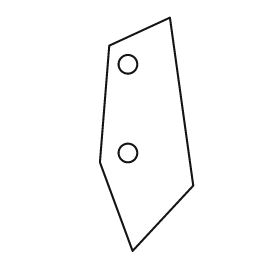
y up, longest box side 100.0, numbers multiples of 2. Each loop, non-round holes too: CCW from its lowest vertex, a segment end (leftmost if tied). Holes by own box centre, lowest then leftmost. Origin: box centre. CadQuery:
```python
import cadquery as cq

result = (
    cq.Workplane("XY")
    .moveTo(-6.0, -50.0)
    .lineTo(20.0, -22.0)
    .lineTo(10.0, 50.0)
    .lineTo(-16.0, 38.0)
    .lineTo(-20.0, -12.0)
    .close()
    .moveTo(-8.0, -8.0)
    .circle(4.0)
    .moveTo(-8.0, 30.0)
    .circle(4.0)
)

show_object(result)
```